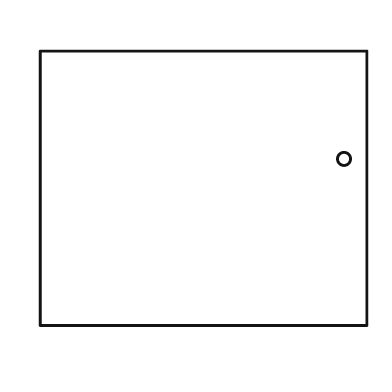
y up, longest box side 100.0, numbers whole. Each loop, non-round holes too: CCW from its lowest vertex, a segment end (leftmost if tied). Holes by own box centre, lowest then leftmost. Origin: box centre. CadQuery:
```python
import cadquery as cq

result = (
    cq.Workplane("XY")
    .moveTo(-50.0, -42.0)
    .lineTo(50.0, -42.0)
    .lineTo(50.0, 42.0)
    .lineTo(-50.0, 42.0)
    .close()
    .moveTo(43.0, 9.0)
    .circle(2.0)
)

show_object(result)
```